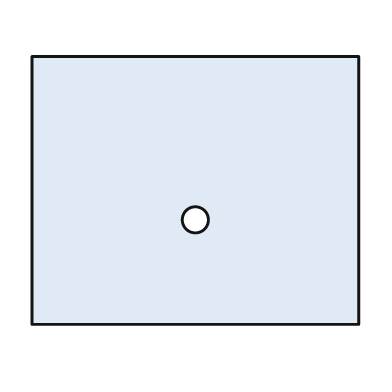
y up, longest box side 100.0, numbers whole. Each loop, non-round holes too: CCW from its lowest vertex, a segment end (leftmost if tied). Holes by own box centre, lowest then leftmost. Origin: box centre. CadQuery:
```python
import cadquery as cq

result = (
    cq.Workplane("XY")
    .moveTo(-50.0, -41.0)
    .lineTo(50.0, -41.0)
    .lineTo(50.0, 41.0)
    .lineTo(-50.0, 41.0)
    .close()
    .moveTo(0.0, -9.0)
    .circle(4.0)
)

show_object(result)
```